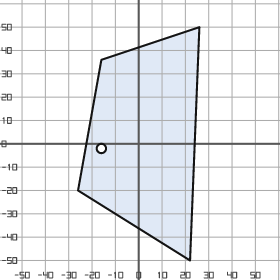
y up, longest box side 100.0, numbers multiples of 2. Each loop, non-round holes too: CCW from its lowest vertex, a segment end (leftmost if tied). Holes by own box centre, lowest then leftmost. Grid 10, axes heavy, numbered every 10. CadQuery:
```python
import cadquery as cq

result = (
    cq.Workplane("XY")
    .moveTo(22.0, -50.0)
    .lineTo(26.0, 50.0)
    .lineTo(-16.0, 36.0)
    .lineTo(-26.0, -20.0)
    .close()
    .moveTo(-16.0, -2.0)
    .circle(2.0)
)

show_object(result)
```